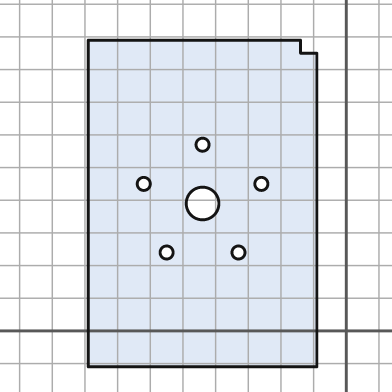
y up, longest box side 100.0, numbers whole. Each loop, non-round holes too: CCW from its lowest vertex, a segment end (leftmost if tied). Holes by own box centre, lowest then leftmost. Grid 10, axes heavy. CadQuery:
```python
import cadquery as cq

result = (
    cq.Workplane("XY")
    .moveTo(-79.0, -11.0)
    .lineTo(-9.0, -11.0)
    .lineTo(-9.0, 85.0)
    .lineTo(-14.0, 85.0)
    .lineTo(-14.0, 89.0)
    .lineTo(-79.0, 89.0)
    .close()
    .moveTo(-55.0, 24.0)
    .circle(2.0)
    .moveTo(-33.0, 24.0)
    .circle(2.0)
    .moveTo(-44.0, 39.0)
    .circle(5.0)
    .moveTo(-62.0, 45.0)
    .circle(2.0)
    .moveTo(-26.0, 45.0)
    .circle(2.0)
    .moveTo(-44.0, 57.0)
    .circle(2.0)
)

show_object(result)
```